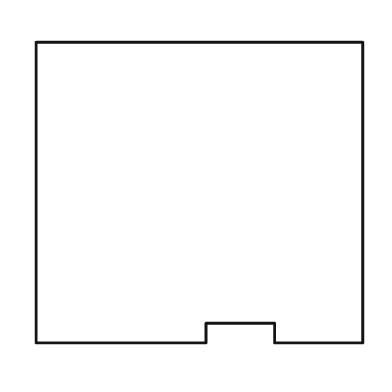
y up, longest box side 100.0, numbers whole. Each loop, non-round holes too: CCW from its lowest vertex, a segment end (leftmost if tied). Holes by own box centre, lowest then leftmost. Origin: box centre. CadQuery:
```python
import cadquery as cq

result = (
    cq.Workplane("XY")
    .moveTo(-50.0, -46.0)
    .lineTo(2.0, -46.0)
    .lineTo(2.0, -40.0)
    .lineTo(23.0, -40.0)
    .lineTo(23.0, -46.0)
    .lineTo(50.0, -46.0)
    .lineTo(50.0, 46.0)
    .lineTo(-50.0, 46.0)
    .close()
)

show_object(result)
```